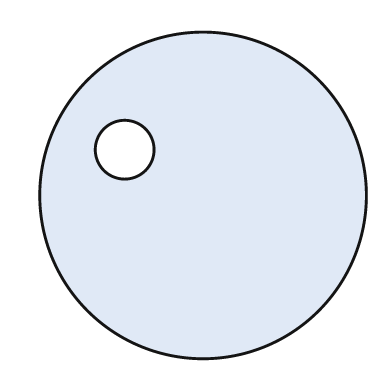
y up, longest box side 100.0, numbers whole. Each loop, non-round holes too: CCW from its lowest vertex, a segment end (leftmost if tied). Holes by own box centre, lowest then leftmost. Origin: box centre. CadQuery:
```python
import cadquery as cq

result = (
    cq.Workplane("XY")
    .moveTo(0.0, 0.0)
    .circle(50.0)
    .moveTo(-24.0, 14.0)
    .circle(9.0)
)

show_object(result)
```